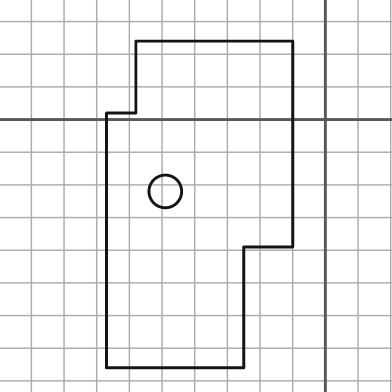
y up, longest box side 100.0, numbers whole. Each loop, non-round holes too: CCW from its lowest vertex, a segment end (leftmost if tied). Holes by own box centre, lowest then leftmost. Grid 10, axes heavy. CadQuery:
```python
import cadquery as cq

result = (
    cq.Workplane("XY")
    .moveTo(-67.0, -76.0)
    .lineTo(-25.0, -76.0)
    .lineTo(-25.0, -39.0)
    .lineTo(-10.0, -39.0)
    .lineTo(-10.0, 24.0)
    .lineTo(-58.0, 24.0)
    .lineTo(-58.0, 2.0)
    .lineTo(-67.0, 2.0)
    .close()
    .moveTo(-49.0, -22.0)
    .circle(5.0)
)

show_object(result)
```